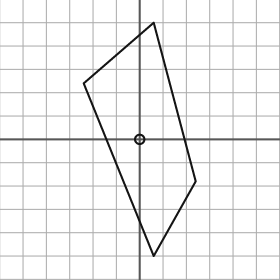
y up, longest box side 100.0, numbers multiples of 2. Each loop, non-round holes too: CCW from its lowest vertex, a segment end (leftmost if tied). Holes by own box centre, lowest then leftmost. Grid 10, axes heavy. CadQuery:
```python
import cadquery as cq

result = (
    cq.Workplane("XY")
    .moveTo(6.0, -50.0)
    .lineTo(24.0, -18.0)
    .lineTo(6.0, 50.0)
    .lineTo(-24.0, 24.0)
    .close()
    .moveTo(0.0, 0.0)
    .circle(2.0)
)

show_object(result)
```